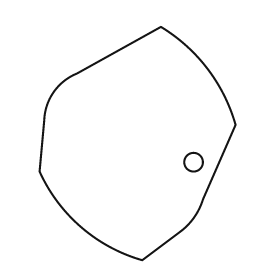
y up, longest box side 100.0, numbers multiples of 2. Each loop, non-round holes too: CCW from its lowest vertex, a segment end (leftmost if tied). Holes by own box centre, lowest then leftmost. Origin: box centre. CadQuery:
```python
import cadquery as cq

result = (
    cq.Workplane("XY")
    .moveTo(2.0, -50.0)
    .lineTo(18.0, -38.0)
    .threePointArc((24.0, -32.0), (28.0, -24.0))
    .lineTo(42.0, 8.0)
    .threePointArc((30.0, 32.0), (10.0, 50.0))
    .lineTo(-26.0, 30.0)
    .threePointArc((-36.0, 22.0), (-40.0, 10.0))
    .lineTo(-42.0, -12.0)
    .threePointArc((-24.0, -36.0), (2.0, -50.0))
    .close()
    .moveTo(24.0, -8.0)
    .circle(4.0)
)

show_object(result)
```